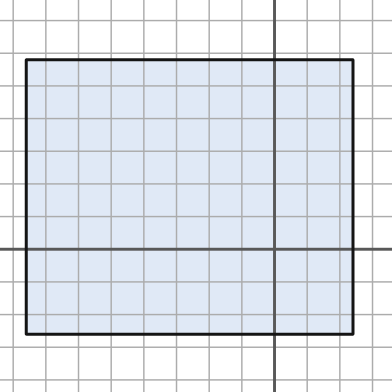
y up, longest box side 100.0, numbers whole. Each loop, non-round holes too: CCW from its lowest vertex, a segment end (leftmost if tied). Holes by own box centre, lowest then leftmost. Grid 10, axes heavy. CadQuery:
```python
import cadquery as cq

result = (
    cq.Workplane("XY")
    .moveTo(-76.0, -26.0)
    .lineTo(24.0, -26.0)
    .lineTo(24.0, 58.0)
    .lineTo(-76.0, 58.0)
    .close()
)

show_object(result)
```